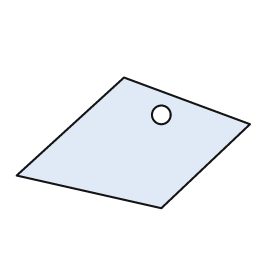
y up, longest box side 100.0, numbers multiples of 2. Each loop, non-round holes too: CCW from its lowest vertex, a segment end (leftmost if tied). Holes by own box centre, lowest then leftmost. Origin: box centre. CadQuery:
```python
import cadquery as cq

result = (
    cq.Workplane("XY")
    .moveTo(12.0, -28.0)
    .lineTo(50.0, 8.0)
    .lineTo(-4.0, 28.0)
    .lineTo(-50.0, -14.0)
    .close()
    .moveTo(12.0, 12.0)
    .circle(4.0)
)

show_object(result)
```